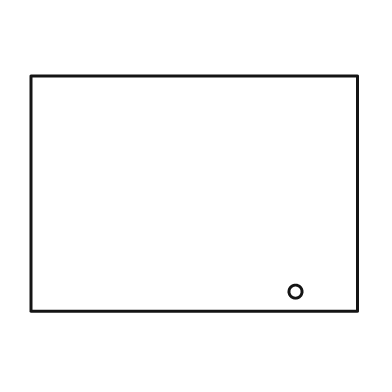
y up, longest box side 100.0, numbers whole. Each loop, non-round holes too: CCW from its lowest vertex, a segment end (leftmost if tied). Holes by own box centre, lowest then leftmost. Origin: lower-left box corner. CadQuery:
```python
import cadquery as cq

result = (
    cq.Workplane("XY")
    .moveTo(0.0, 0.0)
    .lineTo(100.0, 0.0)
    .lineTo(100.0, 72.0)
    .lineTo(0.0, 72.0)
    .close()
    .moveTo(81.0, 6.0)
    .circle(2.0)
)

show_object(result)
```